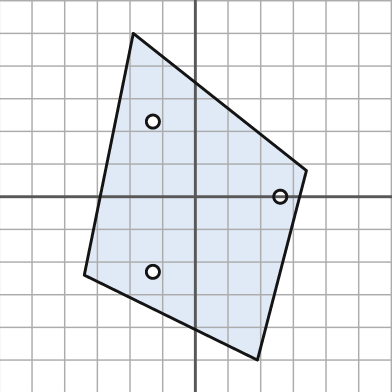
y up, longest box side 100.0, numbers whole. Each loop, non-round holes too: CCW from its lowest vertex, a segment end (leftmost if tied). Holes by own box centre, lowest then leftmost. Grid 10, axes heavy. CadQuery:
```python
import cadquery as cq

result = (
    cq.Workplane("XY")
    .moveTo(19.0, -50.0)
    .lineTo(34.0, 8.0)
    .lineTo(-19.0, 50.0)
    .lineTo(-34.0, -24.0)
    .close()
    .moveTo(-13.0, -23.0)
    .circle(2.0)
    .moveTo(26.0, 0.0)
    .circle(2.0)
    .moveTo(-13.0, 23.0)
    .circle(2.0)
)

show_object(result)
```